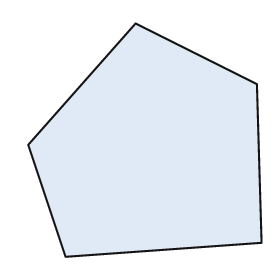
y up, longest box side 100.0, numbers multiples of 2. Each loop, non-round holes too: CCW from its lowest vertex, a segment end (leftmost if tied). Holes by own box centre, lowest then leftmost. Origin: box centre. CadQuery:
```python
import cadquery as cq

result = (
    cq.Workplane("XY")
    .moveTo(-34.0, -50.0)
    .lineTo(50.0, -44.0)
    .lineTo(48.0, 24.0)
    .lineTo(-4.0, 50.0)
    .lineTo(-50.0, -2.0)
    .close()
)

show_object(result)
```